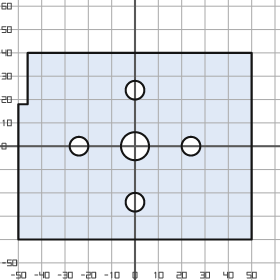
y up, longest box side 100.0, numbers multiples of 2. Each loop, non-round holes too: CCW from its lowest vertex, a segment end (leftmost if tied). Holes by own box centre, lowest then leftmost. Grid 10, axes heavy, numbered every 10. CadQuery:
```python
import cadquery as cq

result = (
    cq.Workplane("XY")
    .moveTo(-50.0, -40.0)
    .lineTo(50.0, -40.0)
    .lineTo(50.0, 40.0)
    .lineTo(-46.0, 40.0)
    .lineTo(-46.0, 18.0)
    .lineTo(-50.0, 18.0)
    .close()
    .moveTo(0.0, -24.0)
    .circle(4.0)
    .moveTo(-24.0, 0.0)
    .circle(4.0)
    .moveTo(0.0, 0.0)
    .circle(6.0)
    .moveTo(24.0, 0.0)
    .circle(4.0)
    .moveTo(0.0, 24.0)
    .circle(4.0)
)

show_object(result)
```